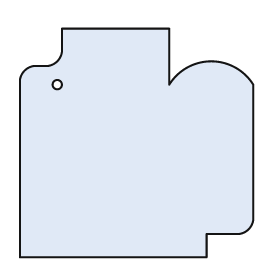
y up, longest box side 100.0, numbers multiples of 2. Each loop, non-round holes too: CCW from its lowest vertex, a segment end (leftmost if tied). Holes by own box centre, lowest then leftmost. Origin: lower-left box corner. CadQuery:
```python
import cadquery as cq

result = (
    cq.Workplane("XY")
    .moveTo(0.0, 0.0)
    .lineTo(80.0, 0.0)
    .lineTo(80.0, 10.0)
    .lineTo(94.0, 10.0)
    .threePointArc((98.0, 12.0), (100.0, 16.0))
    .lineTo(100.0, 74.0)
    .threePointArc((82.0, 84.0), (64.0, 74.0))
    .lineTo(64.0, 98.0)
    .lineTo(18.0, 98.0)
    .lineTo(18.0, 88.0)
    .threePointArc((16.0, 84.0), (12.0, 82.0))
    .lineTo(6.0, 82.0)
    .threePointArc((2.0, 80.0), (0.0, 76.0))
    .close()
    .moveTo(16.0, 74.0)
    .circle(2.0)
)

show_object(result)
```